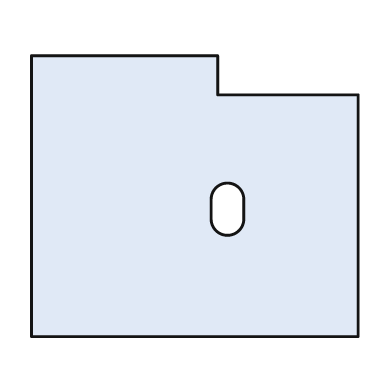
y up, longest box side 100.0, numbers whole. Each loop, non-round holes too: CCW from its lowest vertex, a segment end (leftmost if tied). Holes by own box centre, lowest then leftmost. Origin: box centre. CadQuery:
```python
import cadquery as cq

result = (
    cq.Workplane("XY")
    .moveTo(-50.0, -43.0)
    .lineTo(50.0, -43.0)
    .lineTo(50.0, 31.0)
    .lineTo(7.0, 31.0)
    .lineTo(7.0, 43.0)
    .lineTo(-50.0, 43.0)
    .close()
    .moveTo(5.0, -7.0)
    .threePointArc((10.0, -12.0), (15.0, -7.0))
    .lineTo(15.0, -1.0)
    .threePointArc((10.0, 4.0), (5.0, -1.0))
    .close()
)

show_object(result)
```